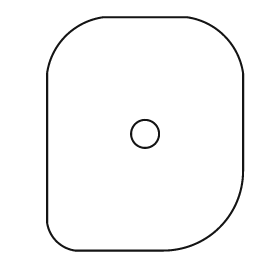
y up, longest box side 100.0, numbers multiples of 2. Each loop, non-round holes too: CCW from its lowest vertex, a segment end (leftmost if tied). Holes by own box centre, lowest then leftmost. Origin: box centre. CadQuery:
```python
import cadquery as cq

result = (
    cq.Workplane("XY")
    .moveTo(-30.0, -50.0)
    .lineTo(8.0, -50.0)
    .threePointArc((32.0, -40.0), (42.0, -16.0))
    .lineTo(42.0, 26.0)
    .threePointArc((34.0, 42.0), (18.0, 50.0))
    .lineTo(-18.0, 50.0)
    .threePointArc((-34.0, 42.0), (-42.0, 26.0))
    .lineTo(-42.0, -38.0)
    .threePointArc((-38.0, -46.0), (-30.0, -50.0))
    .close()
    .moveTo(0.0, 0.0)
    .circle(6.0)
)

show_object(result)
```